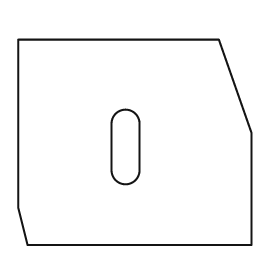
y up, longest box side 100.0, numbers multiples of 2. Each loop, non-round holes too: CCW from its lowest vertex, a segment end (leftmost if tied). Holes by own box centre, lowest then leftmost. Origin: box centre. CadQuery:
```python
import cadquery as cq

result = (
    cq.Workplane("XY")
    .moveTo(-46.0, -44.0)
    .lineTo(50.0, -44.0)
    .lineTo(50.0, 4.0)
    .lineTo(36.0, 44.0)
    .lineTo(-50.0, 44.0)
    .lineTo(-50.0, -28.0)
    .close()
    .moveTo(-10.0, -12.0)
    .threePointArc((-4.0, -18.0), (2.0, -12.0))
    .lineTo(2.0, 8.0)
    .threePointArc((-4.0, 14.0), (-10.0, 8.0))
    .close()
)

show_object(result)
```